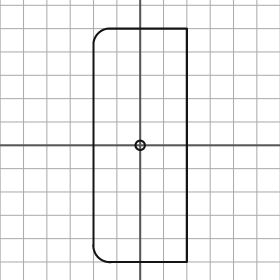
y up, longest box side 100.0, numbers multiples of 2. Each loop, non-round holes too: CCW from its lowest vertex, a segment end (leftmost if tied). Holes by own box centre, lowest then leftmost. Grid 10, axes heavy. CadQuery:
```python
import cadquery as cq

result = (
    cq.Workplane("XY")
    .moveTo(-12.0, -50.0)
    .lineTo(20.0, -50.0)
    .lineTo(20.0, 50.0)
    .lineTo(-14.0, 50.0)
    .threePointArc((-18.0, 48.0), (-20.0, 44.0))
    .lineTo(-20.0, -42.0)
    .threePointArc((-18.0, -48.0), (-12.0, -50.0))
    .close()
    .moveTo(0.0, 0.0)
    .circle(2.0)
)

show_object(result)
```